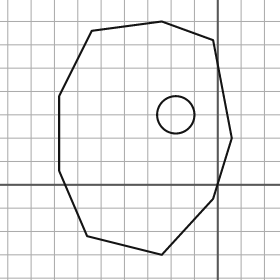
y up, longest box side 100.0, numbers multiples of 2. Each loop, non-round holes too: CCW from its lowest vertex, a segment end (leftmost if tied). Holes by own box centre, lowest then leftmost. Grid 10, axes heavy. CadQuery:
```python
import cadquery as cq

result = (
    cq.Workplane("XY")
    .moveTo(-24.0, -30.0)
    .lineTo(-2.0, -6.0)
    .lineTo(6.0, 20.0)
    .lineTo(-2.0, 62.0)
    .lineTo(-24.0, 70.0)
    .lineTo(-54.0, 66.0)
    .lineTo(-68.0, 38.0)
    .lineTo(-68.0, 6.0)
    .lineTo(-56.0, -22.0)
    .close()
    .moveTo(-18.0, 30.0)
    .circle(8.0)
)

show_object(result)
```